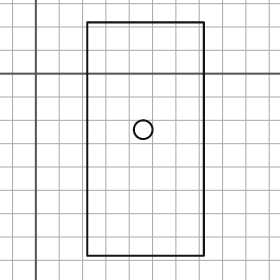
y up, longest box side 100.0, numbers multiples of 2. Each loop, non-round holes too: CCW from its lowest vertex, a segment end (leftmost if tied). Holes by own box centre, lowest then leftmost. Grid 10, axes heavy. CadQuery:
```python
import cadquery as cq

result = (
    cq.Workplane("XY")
    .moveTo(22.0, -78.0)
    .lineTo(72.0, -78.0)
    .lineTo(72.0, 22.0)
    .lineTo(22.0, 22.0)
    .close()
    .moveTo(46.0, -24.0)
    .circle(4.0)
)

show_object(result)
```